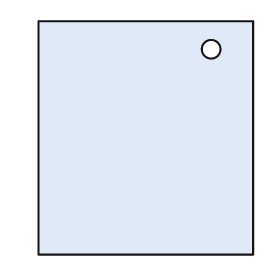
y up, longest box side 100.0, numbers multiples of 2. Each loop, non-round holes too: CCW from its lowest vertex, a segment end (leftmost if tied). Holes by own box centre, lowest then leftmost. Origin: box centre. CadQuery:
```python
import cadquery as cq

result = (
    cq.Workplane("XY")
    .moveTo(-46.0, -50.0)
    .lineTo(46.0, -50.0)
    .lineTo(46.0, 50.0)
    .lineTo(-46.0, 50.0)
    .close()
    .moveTo(28.0, 38.0)
    .circle(4.0)
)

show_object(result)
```